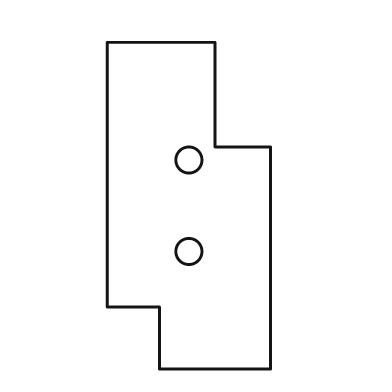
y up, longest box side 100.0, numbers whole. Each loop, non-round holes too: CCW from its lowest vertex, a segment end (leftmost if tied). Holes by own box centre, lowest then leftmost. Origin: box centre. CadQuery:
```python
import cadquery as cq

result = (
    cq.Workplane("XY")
    .moveTo(-9.0, -50.0)
    .lineTo(25.0, -50.0)
    .lineTo(25.0, 18.0)
    .lineTo(8.0, 18.0)
    .lineTo(8.0, 50.0)
    .lineTo(-25.0, 50.0)
    .lineTo(-25.0, -31.0)
    .lineTo(-9.0, -31.0)
    .close()
    .moveTo(0.0, -14.0)
    .circle(4.0)
    .moveTo(0.0, 14.0)
    .circle(4.0)
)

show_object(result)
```